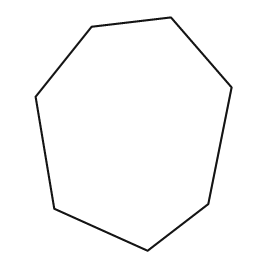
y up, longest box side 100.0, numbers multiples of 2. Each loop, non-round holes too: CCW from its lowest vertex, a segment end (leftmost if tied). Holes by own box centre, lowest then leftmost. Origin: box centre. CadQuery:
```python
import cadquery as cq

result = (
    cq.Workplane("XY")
    .moveTo(6.0, -50.0)
    .lineTo(32.0, -30.0)
    .lineTo(42.0, 20.0)
    .lineTo(16.0, 50.0)
    .lineTo(-18.0, 46.0)
    .lineTo(-42.0, 16.0)
    .lineTo(-34.0, -32.0)
    .close()
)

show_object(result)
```